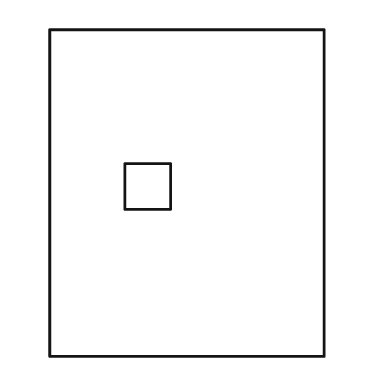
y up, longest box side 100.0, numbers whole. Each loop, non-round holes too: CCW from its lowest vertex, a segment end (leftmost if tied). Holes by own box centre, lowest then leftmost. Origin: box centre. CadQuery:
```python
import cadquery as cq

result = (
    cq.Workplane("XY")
    .moveTo(-42.0, -50.0)
    .lineTo(42.0, -50.0)
    .lineTo(42.0, 50.0)
    .lineTo(-42.0, 50.0)
    .close()
    .moveTo(-19.0, -5.0)
    .lineTo(-5.0, -5.0)
    .lineTo(-5.0, 9.0)
    .lineTo(-19.0, 9.0)
    .close()
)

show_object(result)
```